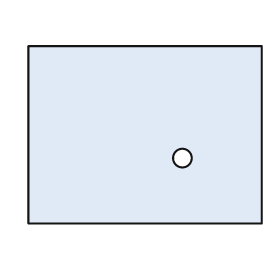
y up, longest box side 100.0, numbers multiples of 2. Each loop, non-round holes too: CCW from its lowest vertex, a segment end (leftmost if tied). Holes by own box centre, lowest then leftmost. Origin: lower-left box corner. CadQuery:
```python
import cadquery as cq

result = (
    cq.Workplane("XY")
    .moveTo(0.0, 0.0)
    .lineTo(100.0, 0.0)
    .lineTo(100.0, 76.0)
    .lineTo(0.0, 76.0)
    .close()
    .moveTo(66.0, 28.0)
    .circle(4.0)
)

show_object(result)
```